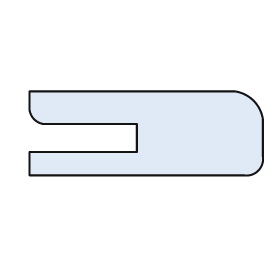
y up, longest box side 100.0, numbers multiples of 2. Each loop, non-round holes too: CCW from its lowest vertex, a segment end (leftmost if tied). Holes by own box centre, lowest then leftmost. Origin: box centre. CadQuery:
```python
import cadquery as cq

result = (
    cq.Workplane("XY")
    .moveTo(-50.0, -18.0)
    .lineTo(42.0, -18.0)
    .threePointArc((48.0, -16.0), (50.0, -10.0))
    .lineTo(50.0, 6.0)
    .threePointArc((46.0, 14.0), (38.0, 18.0))
    .lineTo(-50.0, 18.0)
    .lineTo(-50.0, 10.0)
    .threePointArc((-48.0, 6.0), (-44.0, 4.0))
    .lineTo(-4.0, 4.0)
    .lineTo(-4.0, -8.0)
    .lineTo(-50.0, -8.0)
    .close()
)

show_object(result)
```